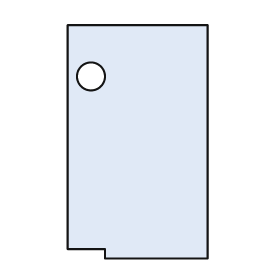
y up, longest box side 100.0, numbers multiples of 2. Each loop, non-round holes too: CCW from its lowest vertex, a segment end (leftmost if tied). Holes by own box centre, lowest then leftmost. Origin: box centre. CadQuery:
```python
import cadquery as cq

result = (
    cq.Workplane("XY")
    .moveTo(-14.0, -50.0)
    .lineTo(30.0, -50.0)
    .lineTo(30.0, 50.0)
    .lineTo(-30.0, 50.0)
    .lineTo(-30.0, -46.0)
    .lineTo(-14.0, -46.0)
    .close()
    .moveTo(-20.0, 28.0)
    .circle(6.0)
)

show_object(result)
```